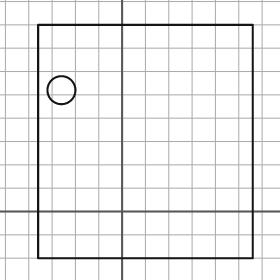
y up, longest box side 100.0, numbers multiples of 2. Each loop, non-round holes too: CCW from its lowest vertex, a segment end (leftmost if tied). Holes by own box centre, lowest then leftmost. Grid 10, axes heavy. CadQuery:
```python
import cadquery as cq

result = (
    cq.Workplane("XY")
    .moveTo(-36.0, -20.0)
    .lineTo(56.0, -20.0)
    .lineTo(56.0, 80.0)
    .lineTo(-36.0, 80.0)
    .close()
    .moveTo(-26.0, 52.0)
    .circle(6.0)
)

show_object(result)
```